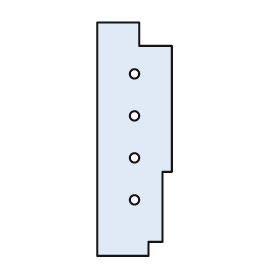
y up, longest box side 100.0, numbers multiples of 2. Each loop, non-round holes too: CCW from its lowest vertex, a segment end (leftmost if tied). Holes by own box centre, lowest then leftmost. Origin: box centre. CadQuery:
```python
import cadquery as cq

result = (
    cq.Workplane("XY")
    .moveTo(-16.0, -50.0)
    .lineTo(6.0, -50.0)
    .lineTo(6.0, -44.0)
    .lineTo(12.0, -44.0)
    .lineTo(12.0, -14.0)
    .lineTo(16.0, -14.0)
    .lineTo(16.0, 40.0)
    .lineTo(2.0, 40.0)
    .lineTo(2.0, 50.0)
    .lineTo(-16.0, 50.0)
    .close()
    .moveTo(0.0, -26.0)
    .circle(2.0)
    .moveTo(0.0, -8.0)
    .circle(2.0)
    .moveTo(0.0, 10.0)
    .circle(2.0)
    .moveTo(0.0, 28.0)
    .circle(2.0)
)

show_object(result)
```